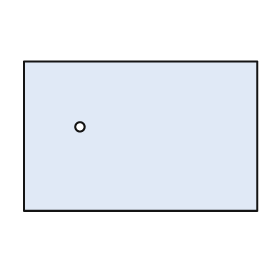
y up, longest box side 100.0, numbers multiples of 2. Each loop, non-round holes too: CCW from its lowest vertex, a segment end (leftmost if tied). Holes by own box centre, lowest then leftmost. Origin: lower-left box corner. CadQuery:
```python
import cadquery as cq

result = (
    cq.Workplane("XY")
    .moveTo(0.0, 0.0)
    .lineTo(100.0, 0.0)
    .lineTo(100.0, 64.0)
    .lineTo(0.0, 64.0)
    .close()
    .moveTo(24.0, 36.0)
    .circle(2.0)
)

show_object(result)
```